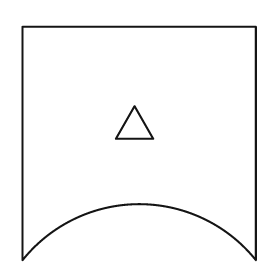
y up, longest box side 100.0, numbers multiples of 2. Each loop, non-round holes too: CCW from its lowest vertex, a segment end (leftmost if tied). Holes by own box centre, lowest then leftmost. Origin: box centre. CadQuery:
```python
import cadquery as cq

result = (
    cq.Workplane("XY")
    .moveTo(-50.0, -50.0)
    .threePointArc((0.0, -26.0), (50.0, -50.0))
    .lineTo(50.0, 50.0)
    .lineTo(-50.0, 50.0)
    .close()
    .moveTo(-10.0, 2.0)
    .lineTo(6.0, 2.0)
    .lineTo(-2.0, 16.0)
    .close()
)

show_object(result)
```